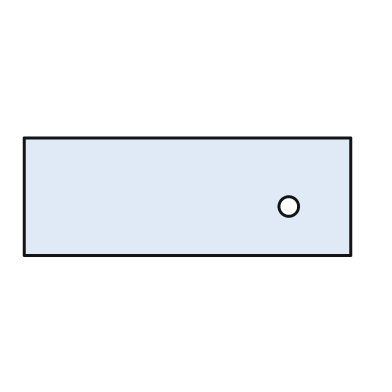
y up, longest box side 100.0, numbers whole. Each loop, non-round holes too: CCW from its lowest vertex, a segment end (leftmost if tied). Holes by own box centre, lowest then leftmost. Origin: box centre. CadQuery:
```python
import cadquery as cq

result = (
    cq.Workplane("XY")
    .moveTo(-50.0, -18.0)
    .lineTo(50.0, -18.0)
    .lineTo(50.0, 18.0)
    .lineTo(-50.0, 18.0)
    .close()
    .moveTo(31.0, -3.0)
    .circle(3.0)
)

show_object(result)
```